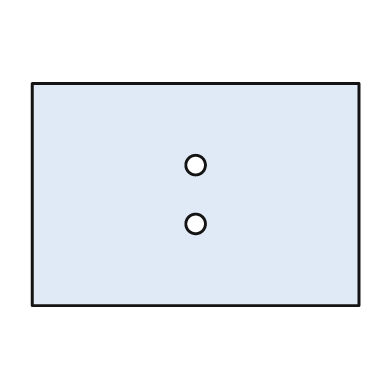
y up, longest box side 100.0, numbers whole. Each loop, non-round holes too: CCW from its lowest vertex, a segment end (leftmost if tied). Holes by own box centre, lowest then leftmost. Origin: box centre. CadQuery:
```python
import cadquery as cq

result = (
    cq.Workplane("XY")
    .moveTo(-50.0, -34.0)
    .lineTo(50.0, -34.0)
    .lineTo(50.0, 34.0)
    .lineTo(-50.0, 34.0)
    .close()
    .moveTo(0.0, -9.0)
    .circle(3.0)
    .moveTo(0.0, 9.0)
    .circle(3.0)
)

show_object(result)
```